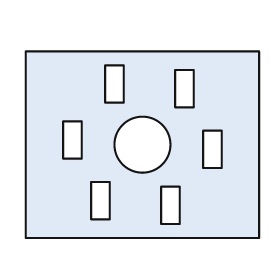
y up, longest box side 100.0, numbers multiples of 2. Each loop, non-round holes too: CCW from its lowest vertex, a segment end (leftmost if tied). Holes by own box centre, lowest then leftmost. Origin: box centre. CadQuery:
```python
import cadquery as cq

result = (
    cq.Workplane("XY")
    .moveTo(-50.0, -40.0)
    .lineTo(50.0, -40.0)
    .lineTo(50.0, 40.0)
    .lineTo(-50.0, 40.0)
    .close()
    .moveTo(8.0, -34.0)
    .lineTo(16.0, -34.0)
    .lineTo(16.0, -18.0)
    .lineTo(8.0, -18.0)
    .close()
    .moveTo(-22.0, -32.0)
    .lineTo(-14.0, -32.0)
    .lineTo(-14.0, -16.0)
    .lineTo(-22.0, -16.0)
    .close()
    .moveTo(26.0, -10.0)
    .lineTo(34.0, -10.0)
    .lineTo(34.0, 6.0)
    .lineTo(26.0, 6.0)
    .close()
    .moveTo(0.0, 0.0)
    .circle(12.0)
    .moveTo(-34.0, -6.0)
    .lineTo(-26.0, -6.0)
    .lineTo(-26.0, 10.0)
    .lineTo(-34.0, 10.0)
    .close()
    .moveTo(14.0, 16.0)
    .lineTo(22.0, 16.0)
    .lineTo(22.0, 32.0)
    .lineTo(14.0, 32.0)
    .close()
    .moveTo(-16.0, 18.0)
    .lineTo(-8.0, 18.0)
    .lineTo(-8.0, 34.0)
    .lineTo(-16.0, 34.0)
    .close()
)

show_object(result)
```